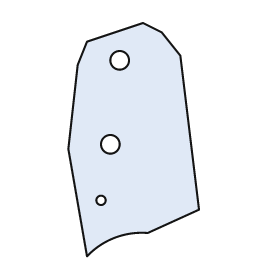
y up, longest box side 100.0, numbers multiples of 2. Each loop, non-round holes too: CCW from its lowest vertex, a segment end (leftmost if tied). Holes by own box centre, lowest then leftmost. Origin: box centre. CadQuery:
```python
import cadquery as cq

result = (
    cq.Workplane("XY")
    .moveTo(-20.0, -50.0)
    .threePointArc((-8.0, -42.0), (6.0, -40.0))
    .lineTo(28.0, -30.0)
    .lineTo(20.0, 36.0)
    .lineTo(12.0, 46.0)
    .lineTo(4.0, 50.0)
    .lineTo(-20.0, 42.0)
    .lineTo(-24.0, 32.0)
    .lineTo(-28.0, -4.0)
    .close()
    .moveTo(-14.0, -26.0)
    .circle(2.0)
    .moveTo(-10.0, -2.0)
    .circle(4.0)
    .moveTo(-6.0, 34.0)
    .circle(4.0)
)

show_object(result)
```